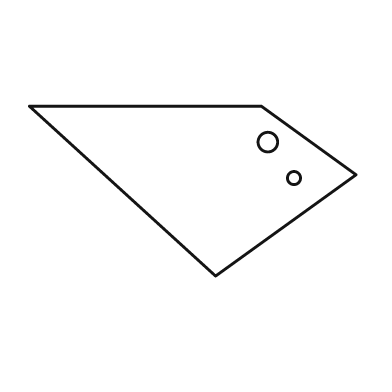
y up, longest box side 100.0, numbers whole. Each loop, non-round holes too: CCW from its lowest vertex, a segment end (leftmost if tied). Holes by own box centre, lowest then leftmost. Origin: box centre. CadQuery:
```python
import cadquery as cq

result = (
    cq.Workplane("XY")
    .moveTo(7.0, -26.0)
    .lineTo(50.0, 5.0)
    .lineTo(21.0, 26.0)
    .lineTo(-50.0, 26.0)
    .close()
    .moveTo(31.0, 4.0)
    .circle(2.0)
    .moveTo(23.0, 15.0)
    .circle(3.0)
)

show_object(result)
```